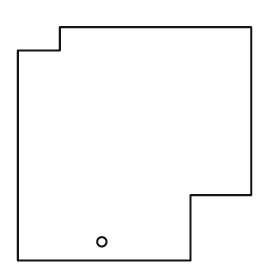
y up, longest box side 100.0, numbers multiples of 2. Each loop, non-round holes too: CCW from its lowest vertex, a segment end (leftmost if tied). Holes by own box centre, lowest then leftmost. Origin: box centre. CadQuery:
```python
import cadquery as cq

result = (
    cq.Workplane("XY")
    .moveTo(-50.0, -50.0)
    .lineTo(24.0, -50.0)
    .lineTo(24.0, -22.0)
    .lineTo(50.0, -22.0)
    .lineTo(50.0, 50.0)
    .lineTo(-32.0, 50.0)
    .lineTo(-32.0, 40.0)
    .lineTo(-50.0, 40.0)
    .close()
    .moveTo(-14.0, -42.0)
    .circle(2.0)
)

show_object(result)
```